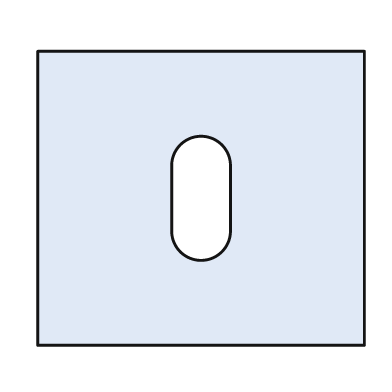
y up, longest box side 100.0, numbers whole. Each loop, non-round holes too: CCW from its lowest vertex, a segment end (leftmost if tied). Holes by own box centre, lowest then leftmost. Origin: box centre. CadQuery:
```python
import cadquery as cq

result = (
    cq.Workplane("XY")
    .moveTo(-50.0, -45.0)
    .lineTo(50.0, -45.0)
    .lineTo(50.0, 45.0)
    .lineTo(-50.0, 45.0)
    .close()
    .moveTo(-9.0, -10.0)
    .threePointArc((0.0, -19.0), (9.0, -10.0))
    .lineTo(9.0, 10.0)
    .threePointArc((0.0, 19.0), (-9.0, 10.0))
    .close()
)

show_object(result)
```